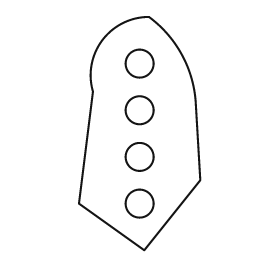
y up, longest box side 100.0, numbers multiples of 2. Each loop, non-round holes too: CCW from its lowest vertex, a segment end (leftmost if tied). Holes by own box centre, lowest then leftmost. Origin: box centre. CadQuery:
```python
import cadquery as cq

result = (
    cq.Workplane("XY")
    .moveTo(2.0, -50.0)
    .lineTo(26.0, -20.0)
    .lineTo(24.0, 14.0)
    .threePointArc((18.0, 34.0), (4.0, 50.0))
    .threePointArc((-16.0, 40.0), (-20.0, 18.0))
    .lineTo(-26.0, -30.0)
    .close()
    .moveTo(0.0, -30.0)
    .circle(6.0)
    .moveTo(0.0, -10.0)
    .circle(6.0)
    .moveTo(0.0, 10.0)
    .circle(6.0)
    .moveTo(0.0, 30.0)
    .circle(6.0)
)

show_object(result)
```